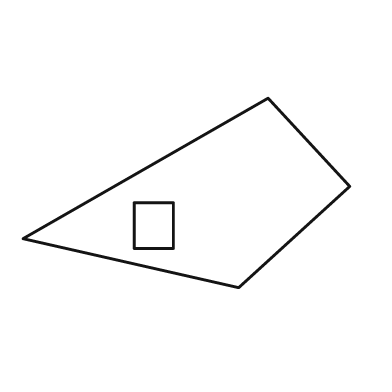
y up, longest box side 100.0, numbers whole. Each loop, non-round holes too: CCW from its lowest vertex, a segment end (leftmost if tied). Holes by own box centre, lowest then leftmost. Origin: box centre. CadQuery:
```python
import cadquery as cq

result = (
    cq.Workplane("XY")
    .moveTo(16.0, -29.0)
    .lineTo(50.0, 2.0)
    .lineTo(25.0, 29.0)
    .lineTo(-50.0, -14.0)
    .close()
    .moveTo(-16.0, -17.0)
    .lineTo(-4.0, -17.0)
    .lineTo(-4.0, -3.0)
    .lineTo(-16.0, -3.0)
    .close()
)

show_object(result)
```